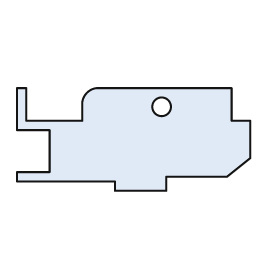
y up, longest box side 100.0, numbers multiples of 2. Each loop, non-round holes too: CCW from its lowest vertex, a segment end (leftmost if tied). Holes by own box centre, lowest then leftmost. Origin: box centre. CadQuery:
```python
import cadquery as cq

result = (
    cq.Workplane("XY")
    .moveTo(-8.0, -22.0)
    .lineTo(14.0, -22.0)
    .lineTo(14.0, -16.0)
    .lineTo(40.0, -16.0)
    .lineTo(50.0, -8.0)
    .lineTo(50.0, 8.0)
    .lineTo(42.0, 8.0)
    .lineTo(42.0, 22.0)
    .lineTo(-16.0, 22.0)
    .threePointArc((-20.0, 20.0), (-22.0, 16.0))
    .lineTo(-22.0, 8.0)
    .lineTo(-46.0, 8.0)
    .lineTo(-46.0, 22.0)
    .lineTo(-50.0, 22.0)
    .lineTo(-50.0, 4.0)
    .lineTo(-36.0, 4.0)
    .lineTo(-36.0, -14.0)
    .lineTo(-50.0, -14.0)
    .lineTo(-50.0, -18.0)
    .lineTo(-8.0, -18.0)
    .close()
    .moveTo(12.0, 14.0)
    .circle(4.0)
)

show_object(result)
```